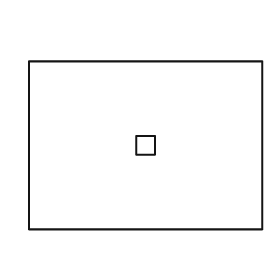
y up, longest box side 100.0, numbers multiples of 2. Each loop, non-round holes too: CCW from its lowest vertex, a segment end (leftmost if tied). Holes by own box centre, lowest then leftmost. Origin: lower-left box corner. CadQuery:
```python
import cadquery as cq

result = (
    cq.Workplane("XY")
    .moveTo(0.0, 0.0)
    .lineTo(100.0, 0.0)
    .lineTo(100.0, 72.0)
    .lineTo(0.0, 72.0)
    .close()
    .moveTo(46.0, 32.0)
    .lineTo(54.0, 32.0)
    .lineTo(54.0, 40.0)
    .lineTo(46.0, 40.0)
    .close()
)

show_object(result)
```